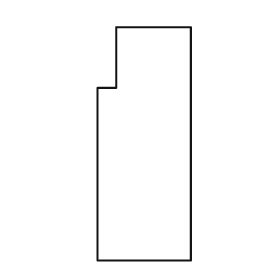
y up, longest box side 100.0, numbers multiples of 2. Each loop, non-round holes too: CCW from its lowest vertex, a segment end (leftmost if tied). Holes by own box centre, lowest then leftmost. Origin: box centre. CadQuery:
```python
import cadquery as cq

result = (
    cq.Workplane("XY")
    .moveTo(-20.0, -50.0)
    .lineTo(20.0, -50.0)
    .lineTo(20.0, 50.0)
    .lineTo(-12.0, 50.0)
    .lineTo(-12.0, 24.0)
    .lineTo(-20.0, 24.0)
    .close()
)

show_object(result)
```